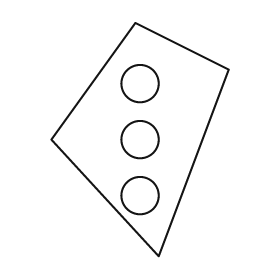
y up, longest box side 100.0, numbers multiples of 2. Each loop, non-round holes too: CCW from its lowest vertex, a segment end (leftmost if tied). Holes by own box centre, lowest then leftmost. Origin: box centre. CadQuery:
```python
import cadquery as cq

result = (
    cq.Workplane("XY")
    .moveTo(8.0, -50.0)
    .lineTo(38.0, 30.0)
    .lineTo(-2.0, 50.0)
    .lineTo(-38.0, 0.0)
    .close()
    .moveTo(0.0, -24.0)
    .circle(8.0)
    .moveTo(0.0, 0.0)
    .circle(8.0)
    .moveTo(0.0, 24.0)
    .circle(8.0)
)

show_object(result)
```